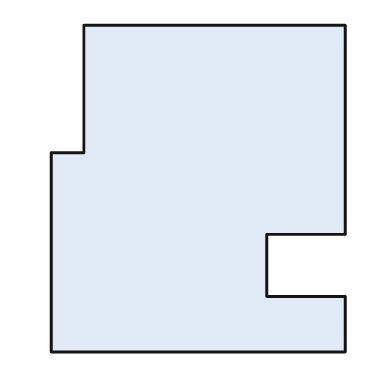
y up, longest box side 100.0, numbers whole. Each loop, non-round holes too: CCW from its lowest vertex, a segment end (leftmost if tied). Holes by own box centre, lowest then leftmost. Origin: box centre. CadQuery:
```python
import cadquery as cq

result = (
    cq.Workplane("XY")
    .moveTo(-45.0, -50.0)
    .lineTo(45.0, -50.0)
    .lineTo(45.0, -33.0)
    .lineTo(21.0, -33.0)
    .lineTo(21.0, -14.0)
    .lineTo(45.0, -14.0)
    .lineTo(45.0, 50.0)
    .lineTo(-35.0, 50.0)
    .lineTo(-35.0, 11.0)
    .lineTo(-45.0, 11.0)
    .close()
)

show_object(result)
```